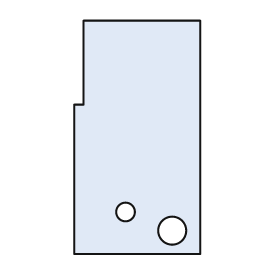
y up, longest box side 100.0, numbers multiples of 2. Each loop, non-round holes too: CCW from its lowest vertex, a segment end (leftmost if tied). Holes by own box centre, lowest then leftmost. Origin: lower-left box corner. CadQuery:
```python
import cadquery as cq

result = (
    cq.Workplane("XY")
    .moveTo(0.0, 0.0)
    .lineTo(54.0, 0.0)
    .lineTo(54.0, 100.0)
    .lineTo(4.0, 100.0)
    .lineTo(4.0, 64.0)
    .lineTo(0.0, 64.0)
    .close()
    .moveTo(42.0, 10.0)
    .circle(6.0)
    .moveTo(22.0, 18.0)
    .circle(4.0)
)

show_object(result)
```